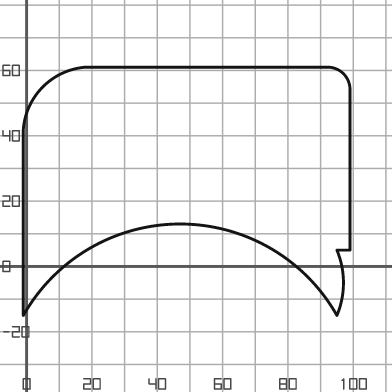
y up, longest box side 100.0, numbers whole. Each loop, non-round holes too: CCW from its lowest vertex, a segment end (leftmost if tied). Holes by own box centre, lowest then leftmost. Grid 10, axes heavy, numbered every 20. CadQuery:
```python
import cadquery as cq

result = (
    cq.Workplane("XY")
    .moveTo(-1.0, -15.0)
    .threePointArc((47.0, 13.0), (95.0, -15.0))
    .threePointArc((97.0, -5.0), (95.0, 5.0))
    .lineTo(99.0, 5.0)
    .lineTo(99.0, 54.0)
    .threePointArc((97.0, 59.0), (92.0, 61.0))
    .lineTo(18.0, 61.0)
    .threePointArc((5.0, 55.0), (-1.0, 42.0))
    .close()
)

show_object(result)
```